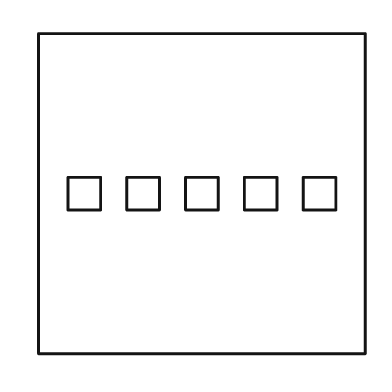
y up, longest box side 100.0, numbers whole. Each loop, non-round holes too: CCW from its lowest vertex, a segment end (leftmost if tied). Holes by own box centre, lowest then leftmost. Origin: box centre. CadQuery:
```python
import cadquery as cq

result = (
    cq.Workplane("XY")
    .moveTo(-50.0, -49.0)
    .lineTo(50.0, -49.0)
    .lineTo(50.0, 49.0)
    .lineTo(-50.0, 49.0)
    .close()
    .moveTo(-41.0, -5.0)
    .lineTo(-31.0, -5.0)
    .lineTo(-31.0, 5.0)
    .lineTo(-41.0, 5.0)
    .close()
    .moveTo(-23.0, -5.0)
    .lineTo(-13.0, -5.0)
    .lineTo(-13.0, 5.0)
    .lineTo(-23.0, 5.0)
    .close()
    .moveTo(-5.0, -5.0)
    .lineTo(5.0, -5.0)
    .lineTo(5.0, 5.0)
    .lineTo(-5.0, 5.0)
    .close()
    .moveTo(13.0, -5.0)
    .lineTo(23.0, -5.0)
    .lineTo(23.0, 5.0)
    .lineTo(13.0, 5.0)
    .close()
    .moveTo(31.0, -5.0)
    .lineTo(41.0, -5.0)
    .lineTo(41.0, 5.0)
    .lineTo(31.0, 5.0)
    .close()
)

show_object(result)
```